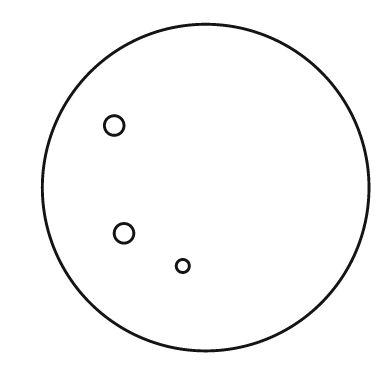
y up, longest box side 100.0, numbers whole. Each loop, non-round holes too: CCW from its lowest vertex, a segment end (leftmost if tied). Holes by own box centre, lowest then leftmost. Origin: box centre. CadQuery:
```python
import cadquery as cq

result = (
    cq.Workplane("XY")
    .moveTo(0.0, 0.0)
    .circle(50.0)
    .moveTo(-7.0, -24.0)
    .circle(2.0)
    .moveTo(-25.0, -14.0)
    .circle(3.0)
    .moveTo(-28.0, 19.0)
    .circle(3.0)
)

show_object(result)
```